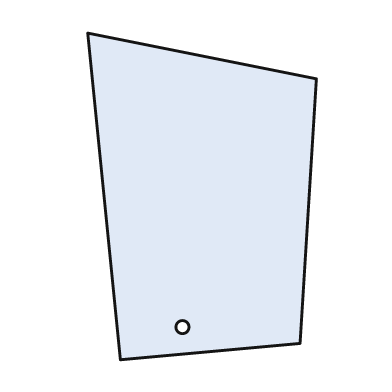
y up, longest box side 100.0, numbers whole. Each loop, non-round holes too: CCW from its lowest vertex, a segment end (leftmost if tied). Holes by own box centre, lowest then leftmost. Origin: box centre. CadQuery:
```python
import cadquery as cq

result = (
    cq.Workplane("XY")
    .moveTo(-25.0, -50.0)
    .lineTo(30.0, -45.0)
    .lineTo(35.0, 36.0)
    .lineTo(-35.0, 50.0)
    .close()
    .moveTo(-6.0, -40.0)
    .circle(2.0)
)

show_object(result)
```